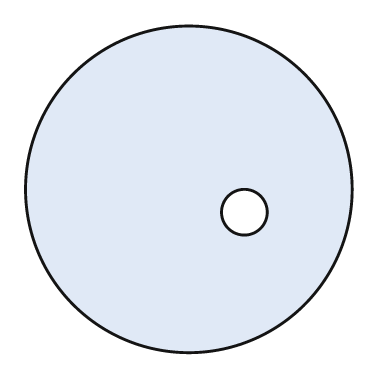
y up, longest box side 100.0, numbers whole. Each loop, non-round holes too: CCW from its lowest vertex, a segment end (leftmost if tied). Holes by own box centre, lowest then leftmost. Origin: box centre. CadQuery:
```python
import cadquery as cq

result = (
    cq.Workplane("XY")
    .moveTo(0.0, 0.0)
    .circle(50.0)
    .moveTo(17.0, -7.0)
    .circle(7.0)
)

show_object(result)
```